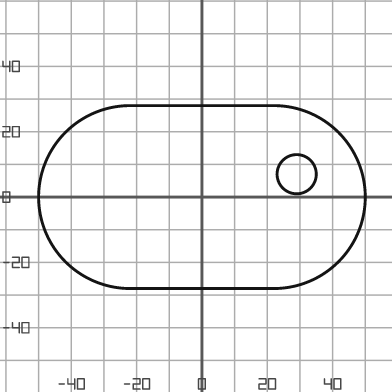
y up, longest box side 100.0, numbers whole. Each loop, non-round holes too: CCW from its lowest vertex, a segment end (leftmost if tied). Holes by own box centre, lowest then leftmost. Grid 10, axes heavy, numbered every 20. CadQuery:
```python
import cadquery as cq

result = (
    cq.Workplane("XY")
    .moveTo(-22.0, -28.0)
    .lineTo(22.0, -28.0)
    .threePointArc((50.0, 0.0), (22.0, 28.0))
    .lineTo(-22.0, 28.0)
    .threePointArc((-50.0, 0.0), (-22.0, -28.0))
    .close()
    .moveTo(29.0, 7.0)
    .circle(6.0)
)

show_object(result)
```